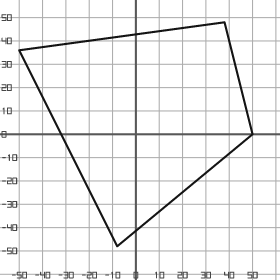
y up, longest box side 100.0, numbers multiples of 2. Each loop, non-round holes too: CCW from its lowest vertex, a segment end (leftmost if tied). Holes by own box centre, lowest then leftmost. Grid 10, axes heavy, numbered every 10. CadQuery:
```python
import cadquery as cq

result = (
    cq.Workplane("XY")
    .moveTo(-8.0, -48.0)
    .lineTo(50.0, 0.0)
    .lineTo(38.0, 48.0)
    .lineTo(-50.0, 36.0)
    .close()
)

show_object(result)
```